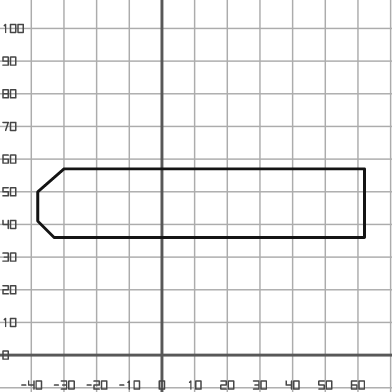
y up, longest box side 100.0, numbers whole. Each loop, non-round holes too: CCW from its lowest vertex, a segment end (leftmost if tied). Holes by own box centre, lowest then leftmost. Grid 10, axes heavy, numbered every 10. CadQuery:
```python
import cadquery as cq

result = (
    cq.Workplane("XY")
    .moveTo(-33.0, 36.0)
    .lineTo(62.0, 36.0)
    .lineTo(62.0, 57.0)
    .lineTo(-30.0, 57.0)
    .lineTo(-38.0, 50.0)
    .lineTo(-38.0, 41.0)
    .close()
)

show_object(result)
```